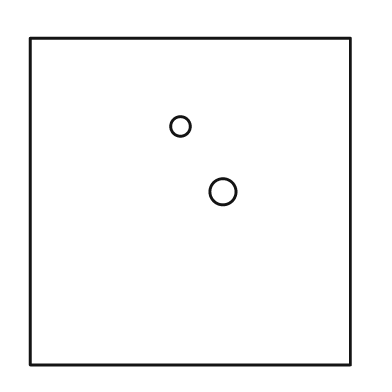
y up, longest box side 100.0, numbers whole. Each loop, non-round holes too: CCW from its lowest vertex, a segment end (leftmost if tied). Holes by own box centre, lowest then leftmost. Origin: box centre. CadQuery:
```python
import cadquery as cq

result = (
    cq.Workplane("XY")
    .moveTo(-49.0, -50.0)
    .lineTo(49.0, -50.0)
    .lineTo(49.0, 50.0)
    .lineTo(-49.0, 50.0)
    .close()
    .moveTo(10.0, 3.0)
    .circle(4.0)
    .moveTo(-3.0, 23.0)
    .circle(3.0)
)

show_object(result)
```